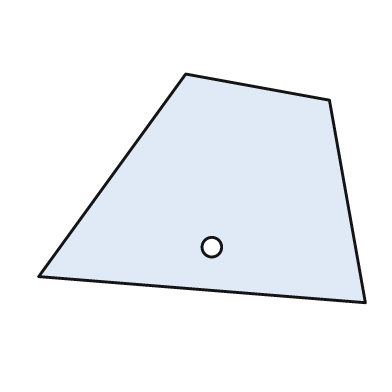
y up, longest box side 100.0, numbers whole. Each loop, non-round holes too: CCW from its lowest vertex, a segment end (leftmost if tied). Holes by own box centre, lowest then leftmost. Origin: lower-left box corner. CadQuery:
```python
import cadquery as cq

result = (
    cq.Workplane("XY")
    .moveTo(100.0, 0.0)
    .lineTo(89.0, 62.0)
    .lineTo(45.0, 70.0)
    .lineTo(0.0, 8.0)
    .close()
    .moveTo(53.0, 17.0)
    .circle(3.0)
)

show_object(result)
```